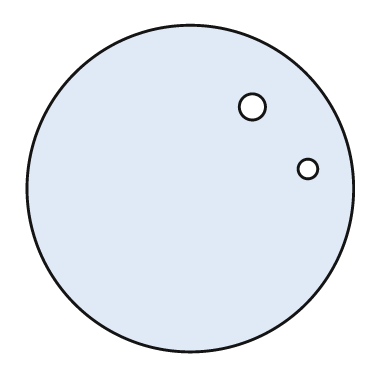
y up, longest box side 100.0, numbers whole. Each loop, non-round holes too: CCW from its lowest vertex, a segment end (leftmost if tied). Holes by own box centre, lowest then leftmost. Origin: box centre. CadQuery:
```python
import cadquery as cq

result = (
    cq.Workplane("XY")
    .moveTo(0.0, 0.0)
    .circle(50.0)
    .moveTo(36.0, 6.0)
    .circle(3.0)
    .moveTo(19.0, 25.0)
    .circle(4.0)
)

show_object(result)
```